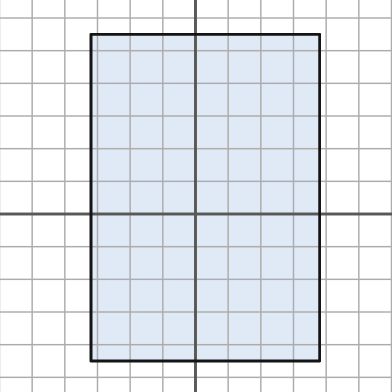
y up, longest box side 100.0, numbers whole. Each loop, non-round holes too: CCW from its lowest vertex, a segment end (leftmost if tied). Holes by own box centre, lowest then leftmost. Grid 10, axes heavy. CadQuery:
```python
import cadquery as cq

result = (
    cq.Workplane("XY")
    .moveTo(-32.0, -45.0)
    .lineTo(38.0, -45.0)
    .lineTo(38.0, 55.0)
    .lineTo(-32.0, 55.0)
    .close()
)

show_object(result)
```